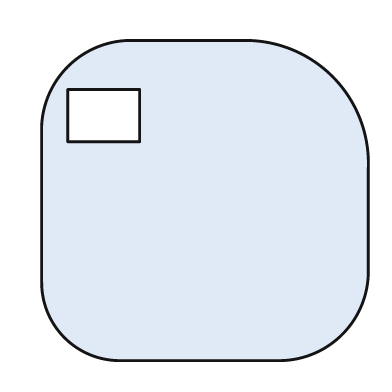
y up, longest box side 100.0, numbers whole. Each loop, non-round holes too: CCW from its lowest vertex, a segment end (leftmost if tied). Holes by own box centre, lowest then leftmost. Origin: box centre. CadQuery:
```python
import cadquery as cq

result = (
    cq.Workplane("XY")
    .moveTo(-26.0, -49.0)
    .lineTo(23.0, -49.0)
    .threePointArc((42.0, -41.0), (50.0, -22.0))
    .lineTo(50.0, 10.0)
    .threePointArc((39.0, 38.0), (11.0, 49.0))
    .lineTo(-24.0, 49.0)
    .threePointArc((-42.0, 41.0), (-50.0, 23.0))
    .lineTo(-50.0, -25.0)
    .threePointArc((-43.0, -42.0), (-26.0, -49.0))
    .close()
    .moveTo(-42.0, 18.0)
    .lineTo(-20.0, 18.0)
    .lineTo(-20.0, 34.0)
    .lineTo(-42.0, 34.0)
    .close()
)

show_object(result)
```